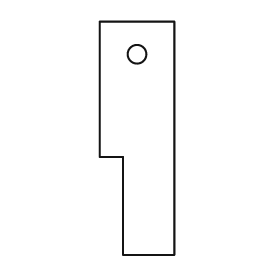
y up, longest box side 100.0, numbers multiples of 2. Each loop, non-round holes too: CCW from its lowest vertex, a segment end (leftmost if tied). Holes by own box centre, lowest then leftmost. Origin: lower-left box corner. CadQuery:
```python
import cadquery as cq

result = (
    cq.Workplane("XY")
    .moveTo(10.0, 0.0)
    .lineTo(32.0, 0.0)
    .lineTo(32.0, 100.0)
    .lineTo(0.0, 100.0)
    .lineTo(0.0, 42.0)
    .lineTo(10.0, 42.0)
    .close()
    .moveTo(16.0, 86.0)
    .circle(4.0)
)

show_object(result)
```